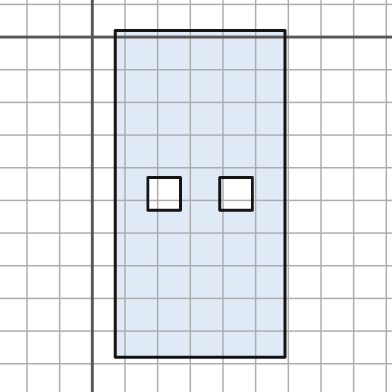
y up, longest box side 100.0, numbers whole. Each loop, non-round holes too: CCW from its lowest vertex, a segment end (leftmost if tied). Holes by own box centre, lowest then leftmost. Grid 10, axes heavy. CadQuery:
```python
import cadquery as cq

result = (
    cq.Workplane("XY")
    .moveTo(7.0, -98.0)
    .lineTo(59.0, -98.0)
    .lineTo(59.0, 2.0)
    .lineTo(7.0, 2.0)
    .close()
    .moveTo(17.0, -53.0)
    .lineTo(27.0, -53.0)
    .lineTo(27.0, -43.0)
    .lineTo(17.0, -43.0)
    .close()
    .moveTo(39.0, -53.0)
    .lineTo(49.0, -53.0)
    .lineTo(49.0, -43.0)
    .lineTo(39.0, -43.0)
    .close()
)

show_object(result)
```